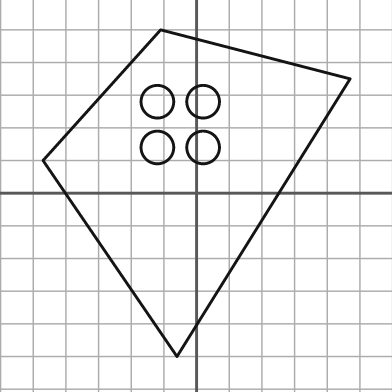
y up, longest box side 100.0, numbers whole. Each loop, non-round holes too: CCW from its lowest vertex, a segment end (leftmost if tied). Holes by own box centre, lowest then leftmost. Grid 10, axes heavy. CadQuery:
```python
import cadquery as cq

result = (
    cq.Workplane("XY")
    .moveTo(-6.0, -50.0)
    .lineTo(47.0, 35.0)
    .lineTo(-11.0, 50.0)
    .lineTo(-47.0, 10.0)
    .close()
    .moveTo(-12.0, 14.0)
    .circle(5.0)
    .moveTo(2.0, 14.0)
    .circle(5.0)
    .moveTo(-12.0, 28.0)
    .circle(5.0)
    .moveTo(2.0, 28.0)
    .circle(5.0)
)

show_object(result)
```